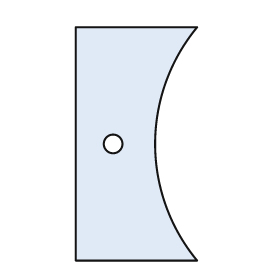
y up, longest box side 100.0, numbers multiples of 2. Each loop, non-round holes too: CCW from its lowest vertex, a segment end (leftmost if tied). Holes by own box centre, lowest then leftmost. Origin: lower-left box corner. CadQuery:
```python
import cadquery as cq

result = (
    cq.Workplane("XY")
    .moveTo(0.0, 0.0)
    .lineTo(52.0, 0.0)
    .threePointArc((34.0, 50.0), (52.0, 100.0))
    .lineTo(0.0, 100.0)
    .close()
    .moveTo(16.0, 50.0)
    .circle(4.0)
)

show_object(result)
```